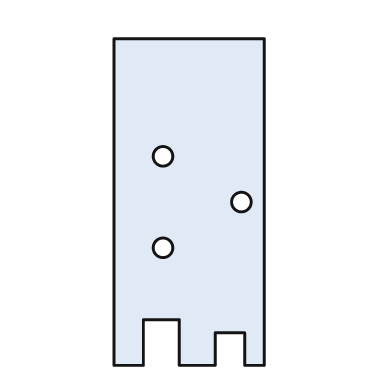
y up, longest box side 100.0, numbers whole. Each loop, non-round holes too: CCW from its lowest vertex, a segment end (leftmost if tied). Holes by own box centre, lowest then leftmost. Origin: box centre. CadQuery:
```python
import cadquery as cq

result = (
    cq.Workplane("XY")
    .moveTo(-23.0, -50.0)
    .lineTo(-14.0, -50.0)
    .lineTo(-14.0, -36.0)
    .lineTo(-3.0, -36.0)
    .lineTo(-3.0, -50.0)
    .lineTo(8.0, -50.0)
    .lineTo(8.0, -40.0)
    .lineTo(17.0, -40.0)
    .lineTo(17.0, -50.0)
    .lineTo(23.0, -50.0)
    .lineTo(23.0, 50.0)
    .lineTo(-23.0, 50.0)
    .close()
    .moveTo(-8.0, -14.0)
    .circle(3.0)
    .moveTo(16.0, 0.0)
    .circle(3.0)
    .moveTo(-8.0, 14.0)
    .circle(3.0)
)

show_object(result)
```